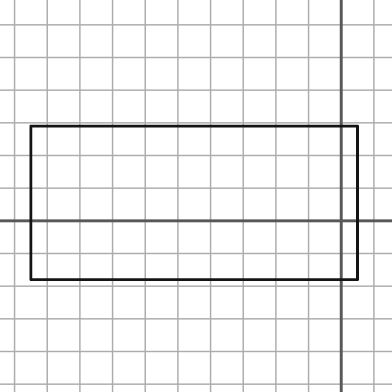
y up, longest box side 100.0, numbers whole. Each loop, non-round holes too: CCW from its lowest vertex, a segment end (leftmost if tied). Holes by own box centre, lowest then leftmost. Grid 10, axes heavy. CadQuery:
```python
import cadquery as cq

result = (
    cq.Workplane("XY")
    .moveTo(-95.0, -18.0)
    .lineTo(5.0, -18.0)
    .lineTo(5.0, 29.0)
    .lineTo(-95.0, 29.0)
    .close()
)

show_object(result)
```